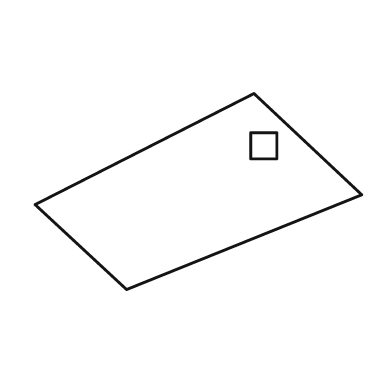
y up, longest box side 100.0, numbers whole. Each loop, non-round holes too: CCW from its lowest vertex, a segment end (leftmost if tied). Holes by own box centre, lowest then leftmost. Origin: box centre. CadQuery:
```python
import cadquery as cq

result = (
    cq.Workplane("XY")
    .moveTo(-22.0, -30.0)
    .lineTo(50.0, -1.0)
    .lineTo(17.0, 30.0)
    .lineTo(-50.0, -4.0)
    .close()
    .moveTo(16.0, 10.0)
    .lineTo(24.0, 10.0)
    .lineTo(24.0, 18.0)
    .lineTo(16.0, 18.0)
    .close()
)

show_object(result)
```